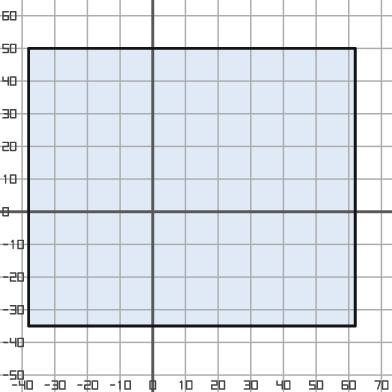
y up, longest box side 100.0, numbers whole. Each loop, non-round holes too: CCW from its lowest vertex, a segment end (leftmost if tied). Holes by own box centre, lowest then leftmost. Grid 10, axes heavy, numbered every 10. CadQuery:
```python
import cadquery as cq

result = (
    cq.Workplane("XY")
    .moveTo(-38.0, -35.0)
    .lineTo(62.0, -35.0)
    .lineTo(62.0, 50.0)
    .lineTo(-38.0, 50.0)
    .close()
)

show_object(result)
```